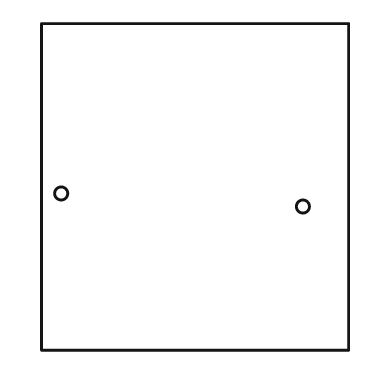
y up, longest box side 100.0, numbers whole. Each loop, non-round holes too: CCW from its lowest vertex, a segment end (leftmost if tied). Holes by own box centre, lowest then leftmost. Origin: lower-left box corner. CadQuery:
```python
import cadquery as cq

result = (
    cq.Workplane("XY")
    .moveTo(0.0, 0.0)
    .lineTo(94.0, 0.0)
    .lineTo(94.0, 100.0)
    .lineTo(0.0, 100.0)
    .close()
    .moveTo(80.0, 44.0)
    .circle(2.0)
    .moveTo(6.0, 48.0)
    .circle(2.0)
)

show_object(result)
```